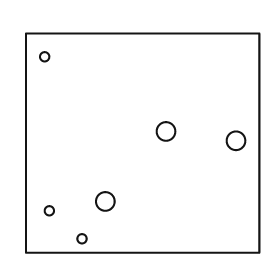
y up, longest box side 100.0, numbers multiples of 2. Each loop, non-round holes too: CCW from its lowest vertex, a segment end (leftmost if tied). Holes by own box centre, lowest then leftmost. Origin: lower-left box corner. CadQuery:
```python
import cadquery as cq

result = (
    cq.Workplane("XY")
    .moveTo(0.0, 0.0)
    .lineTo(100.0, 0.0)
    .lineTo(100.0, 94.0)
    .lineTo(0.0, 94.0)
    .close()
    .moveTo(24.0, 6.0)
    .circle(2.0)
    .moveTo(10.0, 18.0)
    .circle(2.0)
    .moveTo(34.0, 22.0)
    .circle(4.0)
    .moveTo(90.0, 48.0)
    .circle(4.0)
    .moveTo(60.0, 52.0)
    .circle(4.0)
    .moveTo(8.0, 84.0)
    .circle(2.0)
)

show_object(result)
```